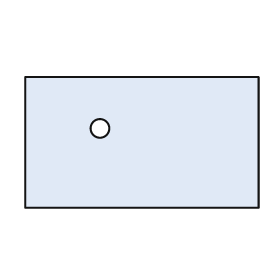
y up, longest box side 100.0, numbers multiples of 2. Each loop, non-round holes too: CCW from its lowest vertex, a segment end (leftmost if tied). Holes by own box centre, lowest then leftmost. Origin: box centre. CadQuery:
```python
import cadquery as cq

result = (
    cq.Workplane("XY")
    .moveTo(-50.0, -28.0)
    .lineTo(50.0, -28.0)
    .lineTo(50.0, 28.0)
    .lineTo(-50.0, 28.0)
    .close()
    .moveTo(-18.0, 6.0)
    .circle(4.0)
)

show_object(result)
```